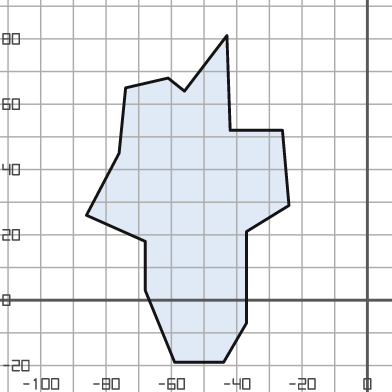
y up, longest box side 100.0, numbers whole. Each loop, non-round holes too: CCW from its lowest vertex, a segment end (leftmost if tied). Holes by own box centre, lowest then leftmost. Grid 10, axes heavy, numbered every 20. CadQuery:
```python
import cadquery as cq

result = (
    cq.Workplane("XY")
    .moveTo(-59.0, -19.0)
    .lineTo(-44.0, -19.0)
    .lineTo(-37.0, -7.0)
    .lineTo(-37.0, 21.0)
    .lineTo(-24.0, 29.0)
    .lineTo(-26.0, 52.0)
    .lineTo(-42.0, 52.0)
    .lineTo(-43.0, 81.0)
    .lineTo(-56.0, 64.0)
    .lineTo(-61.0, 68.0)
    .lineTo(-74.0, 65.0)
    .lineTo(-76.0, 45.0)
    .lineTo(-86.0, 26.0)
    .lineTo(-68.0, 18.0)
    .lineTo(-68.0, 3.0)
    .close()
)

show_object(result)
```